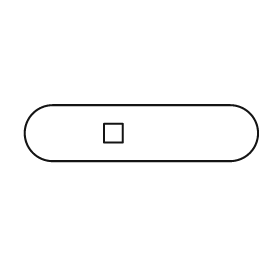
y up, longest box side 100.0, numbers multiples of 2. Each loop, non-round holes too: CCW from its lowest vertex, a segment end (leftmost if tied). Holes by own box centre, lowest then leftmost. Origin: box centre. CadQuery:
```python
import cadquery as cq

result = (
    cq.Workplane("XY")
    .moveTo(-38.0, -12.0)
    .lineTo(38.0, -12.0)
    .threePointArc((50.0, 0.0), (38.0, 12.0))
    .lineTo(-38.0, 12.0)
    .threePointArc((-50.0, 0.0), (-38.0, -12.0))
    .close()
    .moveTo(-16.0, -4.0)
    .lineTo(-8.0, -4.0)
    .lineTo(-8.0, 4.0)
    .lineTo(-16.0, 4.0)
    .close()
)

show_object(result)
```